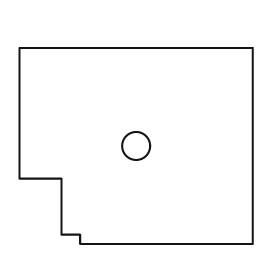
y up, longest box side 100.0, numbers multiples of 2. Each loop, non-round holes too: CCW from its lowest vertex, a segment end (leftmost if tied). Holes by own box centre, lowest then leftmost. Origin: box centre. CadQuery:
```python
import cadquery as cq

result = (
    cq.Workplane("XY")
    .moveTo(-24.0, -42.0)
    .lineTo(50.0, -42.0)
    .lineTo(50.0, 42.0)
    .lineTo(-50.0, 42.0)
    .lineTo(-50.0, -14.0)
    .lineTo(-32.0, -14.0)
    .lineTo(-32.0, -38.0)
    .lineTo(-24.0, -38.0)
    .close()
    .moveTo(0.0, 0.0)
    .circle(6.0)
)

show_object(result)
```